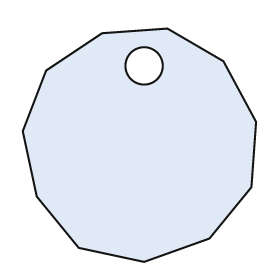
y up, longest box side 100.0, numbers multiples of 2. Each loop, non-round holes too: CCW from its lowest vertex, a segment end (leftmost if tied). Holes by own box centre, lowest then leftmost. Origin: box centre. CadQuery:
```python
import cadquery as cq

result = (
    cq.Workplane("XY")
    .moveTo(2.0, -50.0)
    .lineTo(30.0, -40.0)
    .lineTo(48.0, -18.0)
    .lineTo(50.0, 10.0)
    .lineTo(36.0, 36.0)
    .lineTo(12.0, 50.0)
    .lineTo(-16.0, 48.0)
    .lineTo(-40.0, 32.0)
    .lineTo(-50.0, 6.0)
    .lineTo(-44.0, -22.0)
    .lineTo(-26.0, -44.0)
    .close()
    .moveTo(2.0, 34.0)
    .circle(8.0)
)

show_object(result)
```